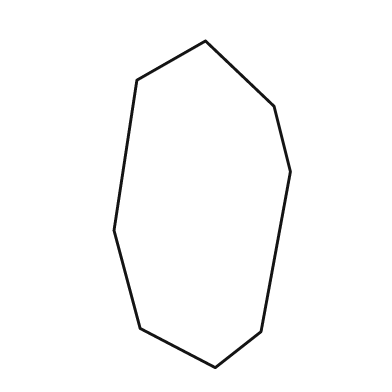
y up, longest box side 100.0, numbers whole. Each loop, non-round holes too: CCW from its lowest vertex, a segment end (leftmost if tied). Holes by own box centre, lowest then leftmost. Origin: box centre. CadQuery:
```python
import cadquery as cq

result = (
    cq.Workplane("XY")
    .moveTo(4.0, -50.0)
    .lineTo(18.0, -39.0)
    .lineTo(27.0, 10.0)
    .lineTo(22.0, 30.0)
    .lineTo(1.0, 50.0)
    .lineTo(-20.0, 38.0)
    .lineTo(-27.0, -8.0)
    .lineTo(-19.0, -38.0)
    .close()
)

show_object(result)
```